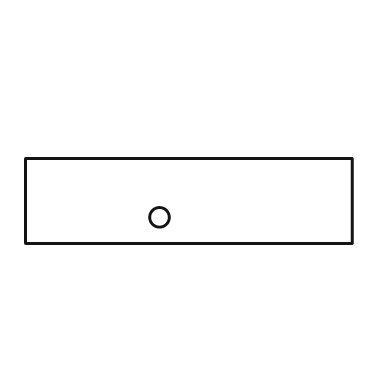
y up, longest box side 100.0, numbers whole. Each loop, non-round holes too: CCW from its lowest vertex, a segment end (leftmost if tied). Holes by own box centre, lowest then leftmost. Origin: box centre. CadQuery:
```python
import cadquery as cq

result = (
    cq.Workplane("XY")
    .moveTo(-50.0, -13.0)
    .lineTo(50.0, -13.0)
    .lineTo(50.0, 13.0)
    .lineTo(-50.0, 13.0)
    .close()
    .moveTo(-9.0, -5.0)
    .circle(3.0)
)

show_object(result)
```